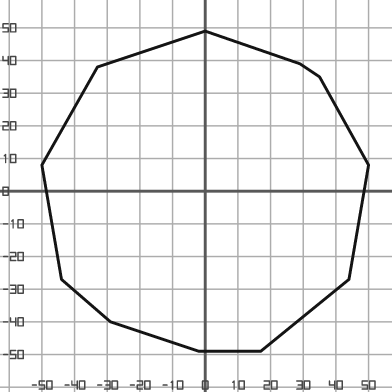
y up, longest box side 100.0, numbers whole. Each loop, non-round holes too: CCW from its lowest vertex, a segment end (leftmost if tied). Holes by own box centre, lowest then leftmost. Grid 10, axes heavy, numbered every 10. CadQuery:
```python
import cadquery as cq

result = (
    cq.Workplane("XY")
    .moveTo(-2.0, -49.0)
    .lineTo(17.0, -49.0)
    .lineTo(44.0, -27.0)
    .lineTo(50.0, 8.0)
    .lineTo(35.0, 35.0)
    .lineTo(29.0, 39.0)
    .lineTo(0.0, 49.0)
    .lineTo(-33.0, 38.0)
    .lineTo(-50.0, 8.0)
    .lineTo(-44.0, -27.0)
    .lineTo(-29.0, -40.0)
    .close()
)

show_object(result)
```